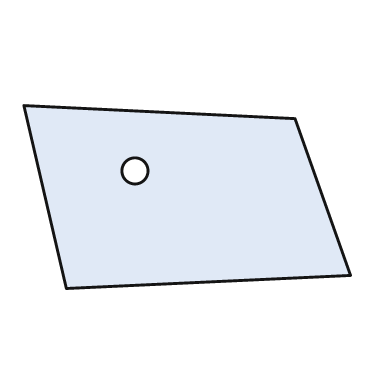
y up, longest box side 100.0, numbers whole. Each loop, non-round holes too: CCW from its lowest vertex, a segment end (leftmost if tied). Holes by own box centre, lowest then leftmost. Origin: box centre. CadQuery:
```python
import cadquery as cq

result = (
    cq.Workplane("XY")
    .moveTo(-37.0, -28.0)
    .lineTo(50.0, -24.0)
    .lineTo(33.0, 24.0)
    .lineTo(-50.0, 28.0)
    .close()
    .moveTo(-16.0, 8.0)
    .circle(4.0)
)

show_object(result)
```